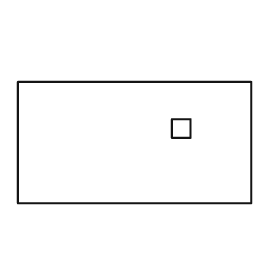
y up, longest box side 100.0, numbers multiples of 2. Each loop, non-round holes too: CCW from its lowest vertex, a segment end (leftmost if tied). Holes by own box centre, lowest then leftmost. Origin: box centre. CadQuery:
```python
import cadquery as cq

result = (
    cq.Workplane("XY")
    .moveTo(-50.0, -26.0)
    .lineTo(50.0, -26.0)
    .lineTo(50.0, 26.0)
    .lineTo(-50.0, 26.0)
    .close()
    .moveTo(16.0, 2.0)
    .lineTo(24.0, 2.0)
    .lineTo(24.0, 10.0)
    .lineTo(16.0, 10.0)
    .close()
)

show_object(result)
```